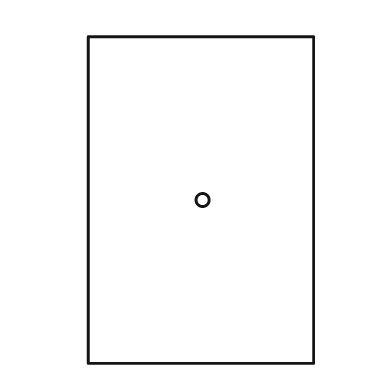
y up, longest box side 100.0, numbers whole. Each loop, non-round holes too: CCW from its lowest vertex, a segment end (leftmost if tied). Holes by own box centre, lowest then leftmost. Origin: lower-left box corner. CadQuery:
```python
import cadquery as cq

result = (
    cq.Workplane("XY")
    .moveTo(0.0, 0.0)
    .lineTo(69.0, 0.0)
    .lineTo(69.0, 100.0)
    .lineTo(0.0, 100.0)
    .close()
    .moveTo(35.0, 50.0)
    .circle(2.0)
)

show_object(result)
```